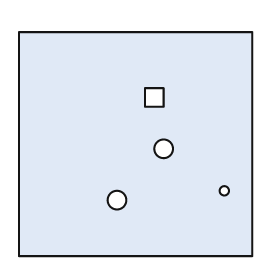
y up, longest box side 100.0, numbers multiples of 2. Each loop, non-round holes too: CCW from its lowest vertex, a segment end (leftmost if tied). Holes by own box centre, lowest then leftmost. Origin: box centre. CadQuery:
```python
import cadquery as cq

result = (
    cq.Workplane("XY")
    .moveTo(-50.0, -48.0)
    .lineTo(50.0, -48.0)
    .lineTo(50.0, 48.0)
    .lineTo(-50.0, 48.0)
    .close()
    .moveTo(-8.0, -24.0)
    .circle(4.0)
    .moveTo(38.0, -20.0)
    .circle(2.0)
    .moveTo(12.0, -2.0)
    .circle(4.0)
    .moveTo(4.0, 16.0)
    .lineTo(12.0, 16.0)
    .lineTo(12.0, 24.0)
    .lineTo(4.0, 24.0)
    .close()
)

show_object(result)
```